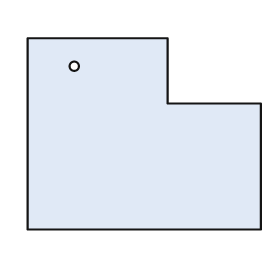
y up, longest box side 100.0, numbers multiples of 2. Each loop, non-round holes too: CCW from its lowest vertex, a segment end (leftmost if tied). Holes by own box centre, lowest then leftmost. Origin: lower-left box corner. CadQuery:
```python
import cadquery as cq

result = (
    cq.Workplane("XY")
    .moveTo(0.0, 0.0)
    .lineTo(100.0, 0.0)
    .lineTo(100.0, 54.0)
    .lineTo(60.0, 54.0)
    .lineTo(60.0, 82.0)
    .lineTo(0.0, 82.0)
    .close()
    .moveTo(20.0, 70.0)
    .circle(2.0)
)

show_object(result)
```